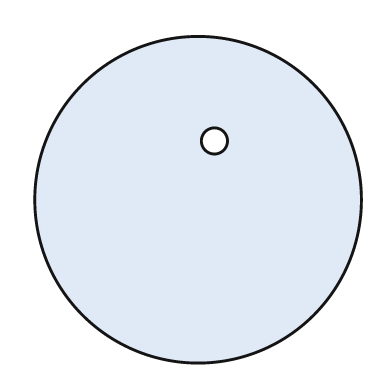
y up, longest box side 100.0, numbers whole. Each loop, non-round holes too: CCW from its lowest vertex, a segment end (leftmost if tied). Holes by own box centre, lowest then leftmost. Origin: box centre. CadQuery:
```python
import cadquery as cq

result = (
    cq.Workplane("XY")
    .moveTo(0.0, 0.0)
    .circle(50.0)
    .moveTo(5.0, 18.0)
    .circle(4.0)
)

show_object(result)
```